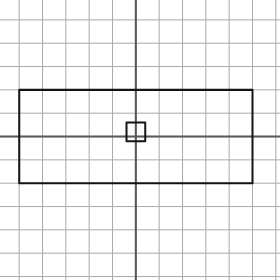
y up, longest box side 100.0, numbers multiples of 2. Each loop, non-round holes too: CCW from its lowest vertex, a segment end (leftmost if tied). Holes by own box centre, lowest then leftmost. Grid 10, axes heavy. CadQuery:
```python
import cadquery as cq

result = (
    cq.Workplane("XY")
    .moveTo(-50.0, -20.0)
    .lineTo(50.0, -20.0)
    .lineTo(50.0, 20.0)
    .lineTo(-50.0, 20.0)
    .close()
    .moveTo(-4.0, -2.0)
    .lineTo(4.0, -2.0)
    .lineTo(4.0, 6.0)
    .lineTo(-4.0, 6.0)
    .close()
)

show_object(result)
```